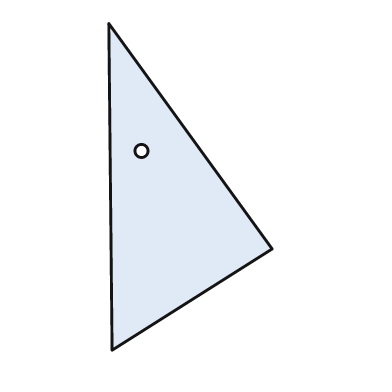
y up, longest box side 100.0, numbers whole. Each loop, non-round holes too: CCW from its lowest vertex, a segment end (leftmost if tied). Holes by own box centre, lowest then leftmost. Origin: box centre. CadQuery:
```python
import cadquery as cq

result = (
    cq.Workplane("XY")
    .moveTo(-24.0, -50.0)
    .lineTo(25.0, -19.0)
    .lineTo(-25.0, 50.0)
    .close()
    .moveTo(-15.0, 11.0)
    .circle(2.0)
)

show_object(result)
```